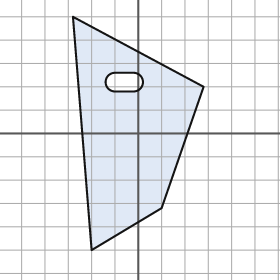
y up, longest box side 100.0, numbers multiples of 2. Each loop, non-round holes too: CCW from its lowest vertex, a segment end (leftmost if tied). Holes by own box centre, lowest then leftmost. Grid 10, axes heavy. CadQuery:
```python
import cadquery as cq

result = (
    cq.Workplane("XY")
    .moveTo(-20.0, -50.0)
    .lineTo(10.0, -32.0)
    .lineTo(28.0, 20.0)
    .lineTo(-28.0, 50.0)
    .close()
    .moveTo(-10.0, 18.0)
    .lineTo(-2.0, 18.0)
    .threePointArc((2.0, 22.0), (-2.0, 26.0))
    .lineTo(-10.0, 26.0)
    .threePointArc((-14.0, 22.0), (-10.0, 18.0))
    .close()
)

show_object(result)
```